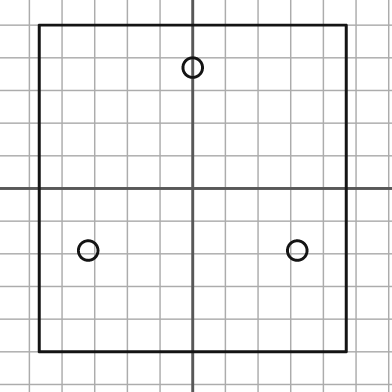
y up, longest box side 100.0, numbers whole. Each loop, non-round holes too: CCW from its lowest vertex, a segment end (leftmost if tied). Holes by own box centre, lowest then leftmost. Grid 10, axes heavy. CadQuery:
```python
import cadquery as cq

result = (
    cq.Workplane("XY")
    .moveTo(-47.0, -50.0)
    .lineTo(47.0, -50.0)
    .lineTo(47.0, 50.0)
    .lineTo(-47.0, 50.0)
    .close()
    .moveTo(-32.0, -19.0)
    .circle(3.0)
    .moveTo(32.0, -19.0)
    .circle(3.0)
    .moveTo(0.0, 37.0)
    .circle(3.0)
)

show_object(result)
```